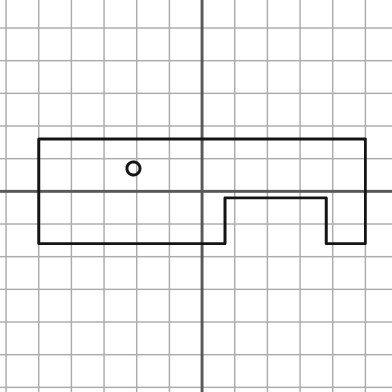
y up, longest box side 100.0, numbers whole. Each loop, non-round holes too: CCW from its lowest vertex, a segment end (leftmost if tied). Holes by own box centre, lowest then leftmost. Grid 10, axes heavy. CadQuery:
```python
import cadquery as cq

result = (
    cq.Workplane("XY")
    .moveTo(-50.0, -16.0)
    .lineTo(7.0, -16.0)
    .lineTo(7.0, -2.0)
    .lineTo(38.0, -2.0)
    .lineTo(38.0, -16.0)
    .lineTo(50.0, -16.0)
    .lineTo(50.0, 16.0)
    .lineTo(-50.0, 16.0)
    .close()
    .moveTo(-21.0, 7.0)
    .circle(2.0)
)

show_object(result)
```